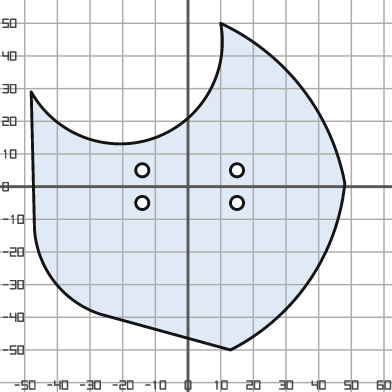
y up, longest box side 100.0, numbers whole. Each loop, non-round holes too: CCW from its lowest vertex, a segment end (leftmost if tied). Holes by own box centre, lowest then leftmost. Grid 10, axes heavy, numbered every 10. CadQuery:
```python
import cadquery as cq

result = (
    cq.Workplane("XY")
    .moveTo(13.0, -50.0)
    .threePointArc((37.0, -29.0), (48.0, 1.0))
    .threePointArc((35.0, 30.0), (10.0, 50.0))
    .threePointArc((-10.0, 15.0), (-48.0, 29.0))
    .lineTo(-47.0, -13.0)
    .threePointArc((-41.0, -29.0), (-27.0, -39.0))
    .close()
    .moveTo(-14.0, -5.0)
    .circle(2.0)
    .moveTo(15.0, -5.0)
    .circle(2.0)
    .moveTo(-14.0, 5.0)
    .circle(2.0)
    .moveTo(15.0, 5.0)
    .circle(2.0)
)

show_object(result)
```